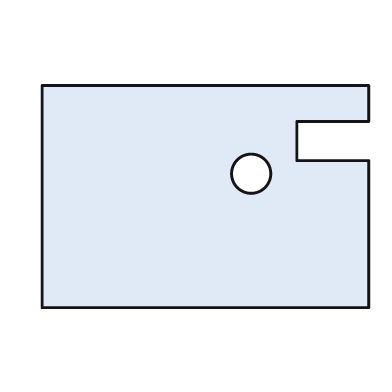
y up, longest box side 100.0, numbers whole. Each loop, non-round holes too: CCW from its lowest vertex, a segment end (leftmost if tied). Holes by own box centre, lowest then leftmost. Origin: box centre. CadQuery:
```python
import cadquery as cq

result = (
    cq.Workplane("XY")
    .moveTo(-50.0, -34.0)
    .lineTo(50.0, -34.0)
    .lineTo(50.0, 11.0)
    .lineTo(28.0, 11.0)
    .lineTo(28.0, 23.0)
    .lineTo(50.0, 23.0)
    .lineTo(50.0, 34.0)
    .lineTo(-50.0, 34.0)
    .close()
    .moveTo(14.0, 7.0)
    .circle(6.0)
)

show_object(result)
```